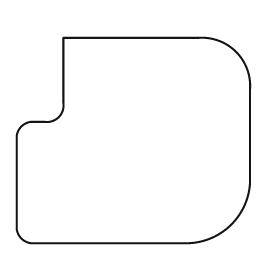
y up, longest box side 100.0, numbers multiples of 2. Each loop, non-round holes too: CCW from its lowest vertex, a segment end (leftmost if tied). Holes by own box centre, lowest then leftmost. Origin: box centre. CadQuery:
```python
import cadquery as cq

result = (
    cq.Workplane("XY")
    .moveTo(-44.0, -44.0)
    .lineTo(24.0, -44.0)
    .threePointArc((42.0, -36.0), (50.0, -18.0))
    .lineTo(50.0, 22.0)
    .threePointArc((44.0, 38.0), (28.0, 44.0))
    .lineTo(-30.0, 44.0)
    .lineTo(-30.0, 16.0)
    .threePointArc((-32.0, 10.0), (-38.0, 8.0))
    .lineTo(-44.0, 8.0)
    .threePointArc((-48.0, 6.0), (-50.0, 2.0))
    .lineTo(-50.0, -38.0)
    .threePointArc((-48.0, -42.0), (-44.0, -44.0))
    .close()
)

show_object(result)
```